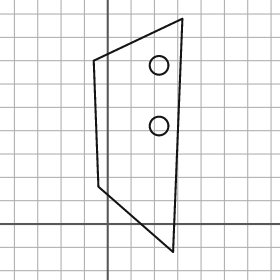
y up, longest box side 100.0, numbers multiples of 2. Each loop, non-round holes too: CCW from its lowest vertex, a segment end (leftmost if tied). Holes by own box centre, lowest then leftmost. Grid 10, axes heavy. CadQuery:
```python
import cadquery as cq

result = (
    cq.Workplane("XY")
    .moveTo(28.0, -12.0)
    .lineTo(32.0, 88.0)
    .lineTo(-6.0, 70.0)
    .lineTo(-4.0, 16.0)
    .close()
    .moveTo(22.0, 42.0)
    .circle(4.0)
    .moveTo(22.0, 68.0)
    .circle(4.0)
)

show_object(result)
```